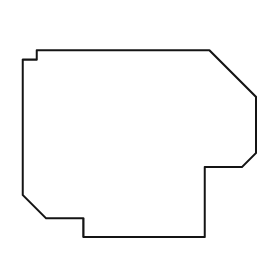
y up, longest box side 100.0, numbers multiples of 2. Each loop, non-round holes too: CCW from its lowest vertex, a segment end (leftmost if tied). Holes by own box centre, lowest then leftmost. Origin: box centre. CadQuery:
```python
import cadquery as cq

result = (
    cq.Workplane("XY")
    .moveTo(-24.0, -40.0)
    .lineTo(28.0, -40.0)
    .lineTo(28.0, -10.0)
    .lineTo(44.0, -10.0)
    .lineTo(50.0, -4.0)
    .lineTo(50.0, 20.0)
    .lineTo(30.0, 40.0)
    .lineTo(-44.0, 40.0)
    .lineTo(-44.0, 36.0)
    .lineTo(-50.0, 36.0)
    .lineTo(-50.0, -22.0)
    .lineTo(-40.0, -32.0)
    .lineTo(-24.0, -32.0)
    .close()
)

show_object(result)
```